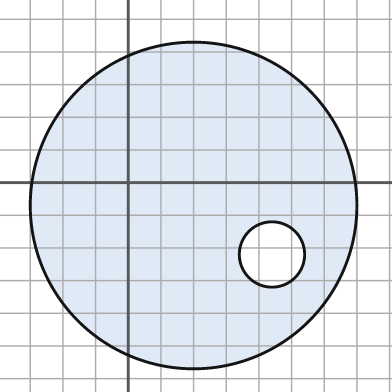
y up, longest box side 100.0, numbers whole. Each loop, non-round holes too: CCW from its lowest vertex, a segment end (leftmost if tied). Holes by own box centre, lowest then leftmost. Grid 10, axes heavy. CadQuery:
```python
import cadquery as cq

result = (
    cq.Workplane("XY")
    .moveTo(20.0, -7.0)
    .circle(50.0)
    .moveTo(44.0, -22.0)
    .circle(10.0)
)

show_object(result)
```